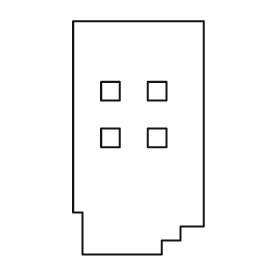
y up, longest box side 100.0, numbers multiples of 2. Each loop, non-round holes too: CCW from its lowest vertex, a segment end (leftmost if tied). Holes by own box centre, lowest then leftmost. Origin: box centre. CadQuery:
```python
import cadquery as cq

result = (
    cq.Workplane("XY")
    .moveTo(-24.0, -50.0)
    .lineTo(10.0, -50.0)
    .lineTo(10.0, -44.0)
    .lineTo(18.0, -44.0)
    .lineTo(18.0, -38.0)
    .lineTo(28.0, -38.0)
    .lineTo(28.0, 50.0)
    .lineTo(-28.0, 50.0)
    .lineTo(-28.0, -32.0)
    .lineTo(-24.0, -32.0)
    .close()
    .moveTo(-16.0, -4.0)
    .lineTo(-8.0, -4.0)
    .lineTo(-8.0, 4.0)
    .lineTo(-16.0, 4.0)
    .close()
    .moveTo(4.0, -4.0)
    .lineTo(12.0, -4.0)
    .lineTo(12.0, 4.0)
    .lineTo(4.0, 4.0)
    .close()
    .moveTo(-16.0, 16.0)
    .lineTo(-8.0, 16.0)
    .lineTo(-8.0, 24.0)
    .lineTo(-16.0, 24.0)
    .close()
    .moveTo(4.0, 16.0)
    .lineTo(12.0, 16.0)
    .lineTo(12.0, 24.0)
    .lineTo(4.0, 24.0)
    .close()
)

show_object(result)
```